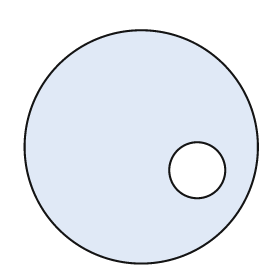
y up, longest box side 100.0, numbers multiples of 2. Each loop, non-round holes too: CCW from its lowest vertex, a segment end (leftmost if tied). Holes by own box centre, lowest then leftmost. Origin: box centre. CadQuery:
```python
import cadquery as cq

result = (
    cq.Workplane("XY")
    .moveTo(0.0, 0.0)
    .circle(50.0)
    .moveTo(24.0, -10.0)
    .circle(12.0)
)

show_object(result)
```